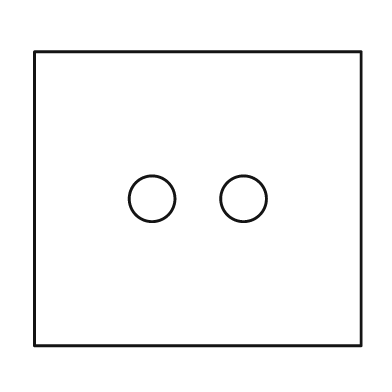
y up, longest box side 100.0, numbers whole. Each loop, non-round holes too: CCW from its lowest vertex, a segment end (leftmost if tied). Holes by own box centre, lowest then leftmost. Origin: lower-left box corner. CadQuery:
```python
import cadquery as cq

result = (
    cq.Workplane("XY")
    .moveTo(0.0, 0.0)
    .lineTo(100.0, 0.0)
    .lineTo(100.0, 90.0)
    .lineTo(0.0, 90.0)
    .close()
    .moveTo(36.0, 45.0)
    .circle(7.0)
    .moveTo(64.0, 45.0)
    .circle(7.0)
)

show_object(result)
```